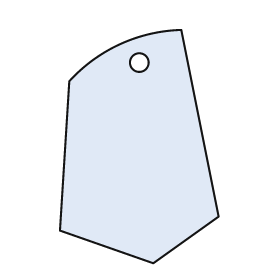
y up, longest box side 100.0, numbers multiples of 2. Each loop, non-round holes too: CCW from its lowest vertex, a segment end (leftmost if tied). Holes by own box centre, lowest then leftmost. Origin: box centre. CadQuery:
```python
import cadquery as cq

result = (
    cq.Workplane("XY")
    .moveTo(6.0, -50.0)
    .lineTo(34.0, -30.0)
    .lineTo(18.0, 50.0)
    .threePointArc((-8.0, 44.0), (-30.0, 28.0))
    .lineTo(-34.0, -36.0)
    .close()
    .moveTo(0.0, 36.0)
    .circle(4.0)
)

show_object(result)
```